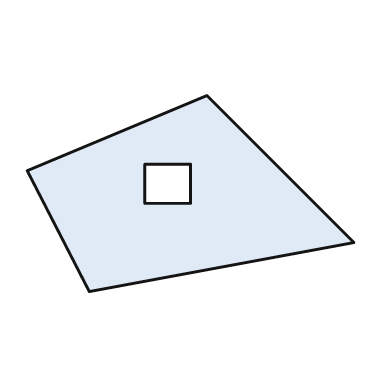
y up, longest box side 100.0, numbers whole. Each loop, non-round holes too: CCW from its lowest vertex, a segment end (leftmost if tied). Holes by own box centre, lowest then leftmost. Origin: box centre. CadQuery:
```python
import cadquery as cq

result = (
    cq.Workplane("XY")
    .moveTo(-31.0, -30.0)
    .lineTo(50.0, -15.0)
    .lineTo(5.0, 30.0)
    .lineTo(-50.0, 7.0)
    .close()
    .moveTo(-14.0, -3.0)
    .lineTo(0.0, -3.0)
    .lineTo(0.0, 9.0)
    .lineTo(-14.0, 9.0)
    .close()
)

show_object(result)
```